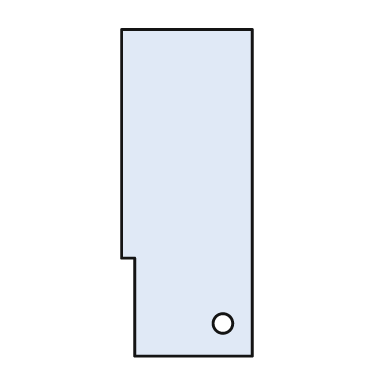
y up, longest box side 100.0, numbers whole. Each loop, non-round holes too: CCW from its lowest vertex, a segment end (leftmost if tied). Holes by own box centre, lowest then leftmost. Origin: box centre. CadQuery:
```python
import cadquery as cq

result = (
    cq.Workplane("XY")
    .moveTo(-16.0, -50.0)
    .lineTo(20.0, -50.0)
    .lineTo(20.0, 50.0)
    .lineTo(-20.0, 50.0)
    .lineTo(-20.0, -20.0)
    .lineTo(-16.0, -20.0)
    .close()
    .moveTo(11.0, -40.0)
    .circle(3.0)
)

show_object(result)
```